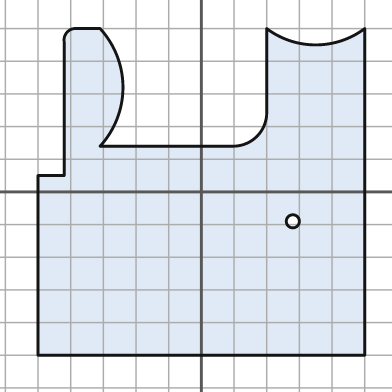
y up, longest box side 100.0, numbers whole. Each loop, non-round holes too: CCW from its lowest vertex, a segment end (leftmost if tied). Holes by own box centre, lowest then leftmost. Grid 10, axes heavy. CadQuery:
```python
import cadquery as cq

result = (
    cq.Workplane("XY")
    .moveTo(-50.0, -50.0)
    .lineTo(50.0, -50.0)
    .lineTo(50.0, 50.0)
    .threePointArc((35.0, 45.0), (20.0, 50.0))
    .lineTo(20.0, 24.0)
    .threePointArc((17.0, 17.0), (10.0, 14.0))
    .lineTo(-31.0, 14.0)
    .threePointArc((-24.0, 32.0), (-31.0, 50.0))
    .lineTo(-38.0, 50.0)
    .threePointArc((-41.0, 49.0), (-42.0, 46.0))
    .lineTo(-42.0, 5.0)
    .lineTo(-50.0, 5.0)
    .close()
    .moveTo(28.0, -9.0)
    .circle(2.0)
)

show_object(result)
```